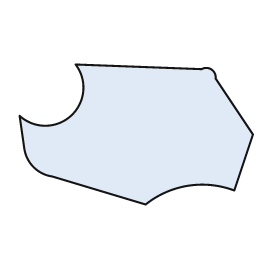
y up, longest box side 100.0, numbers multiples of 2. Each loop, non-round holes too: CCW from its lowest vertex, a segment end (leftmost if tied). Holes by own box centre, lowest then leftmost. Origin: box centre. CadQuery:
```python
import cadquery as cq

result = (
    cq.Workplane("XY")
    .moveTo(4.0, -30.0)
    .threePointArc((22.0, -22.0), (42.0, -24.0))
    .lineTo(50.0, 0.0)
    .lineTo(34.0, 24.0)
    .threePointArc((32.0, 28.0), (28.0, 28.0))
    .lineTo(-26.0, 30.0)
    .threePointArc((-28.0, 8.0), (-50.0, 8.0))
    .lineTo(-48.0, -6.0)
    .threePointArc((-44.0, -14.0), (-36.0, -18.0))
    .close()
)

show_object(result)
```